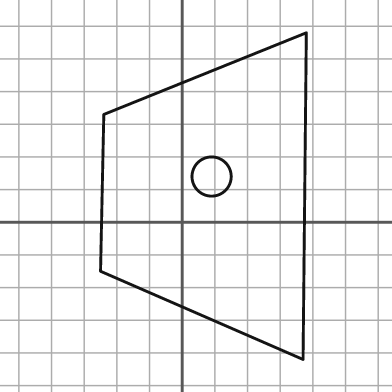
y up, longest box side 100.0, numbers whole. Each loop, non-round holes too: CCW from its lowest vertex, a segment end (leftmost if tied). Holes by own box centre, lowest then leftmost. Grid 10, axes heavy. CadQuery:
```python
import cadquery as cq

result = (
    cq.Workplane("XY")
    .moveTo(37.0, -42.0)
    .lineTo(38.0, 58.0)
    .lineTo(-24.0, 33.0)
    .lineTo(-25.0, -15.0)
    .close()
    .moveTo(9.0, 14.0)
    .circle(6.0)
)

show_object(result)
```